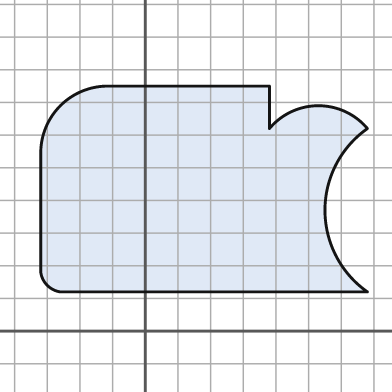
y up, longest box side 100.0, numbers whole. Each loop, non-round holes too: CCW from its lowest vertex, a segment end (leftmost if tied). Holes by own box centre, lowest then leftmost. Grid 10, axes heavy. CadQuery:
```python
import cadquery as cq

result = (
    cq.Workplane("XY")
    .moveTo(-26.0, 12.0)
    .lineTo(68.0, 12.0)
    .threePointArc((55.0, 37.0), (68.0, 62.0))
    .threePointArc((53.0, 69.0), (38.0, 62.0))
    .lineTo(38.0, 75.0)
    .lineTo(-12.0, 75.0)
    .threePointArc((-26.0, 69.0), (-32.0, 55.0))
    .lineTo(-32.0, 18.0)
    .threePointArc((-30.0, 14.0), (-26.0, 12.0))
    .close()
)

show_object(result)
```